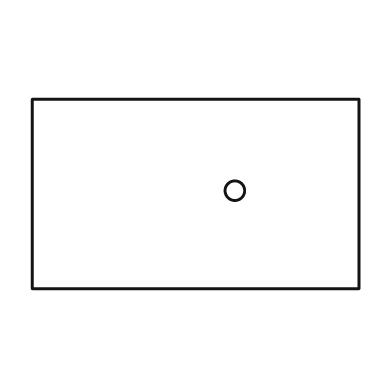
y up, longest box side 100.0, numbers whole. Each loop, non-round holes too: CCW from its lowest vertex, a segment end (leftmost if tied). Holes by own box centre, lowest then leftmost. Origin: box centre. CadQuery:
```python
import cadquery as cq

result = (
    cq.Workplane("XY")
    .moveTo(-50.0, -29.0)
    .lineTo(50.0, -29.0)
    .lineTo(50.0, 29.0)
    .lineTo(-50.0, 29.0)
    .close()
    .moveTo(12.0, 1.0)
    .circle(3.0)
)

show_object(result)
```